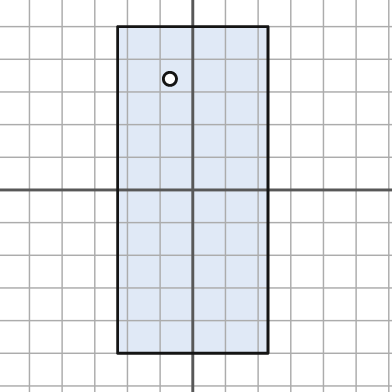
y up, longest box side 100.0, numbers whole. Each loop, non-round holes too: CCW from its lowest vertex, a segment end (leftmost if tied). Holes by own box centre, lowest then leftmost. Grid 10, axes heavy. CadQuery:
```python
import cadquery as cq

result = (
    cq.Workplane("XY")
    .moveTo(-23.0, -50.0)
    .lineTo(23.0, -50.0)
    .lineTo(23.0, 50.0)
    .lineTo(-23.0, 50.0)
    .close()
    .moveTo(-7.0, 34.0)
    .circle(2.0)
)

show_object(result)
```